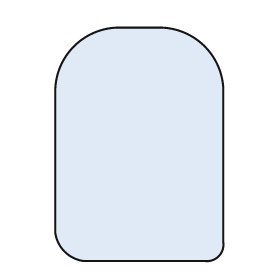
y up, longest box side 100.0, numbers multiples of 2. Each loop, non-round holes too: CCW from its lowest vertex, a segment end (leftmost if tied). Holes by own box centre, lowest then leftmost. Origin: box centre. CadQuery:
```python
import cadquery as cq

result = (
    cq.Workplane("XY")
    .moveTo(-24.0, -50.0)
    .lineTo(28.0, -50.0)
    .threePointArc((34.0, -48.0), (36.0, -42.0))
    .lineTo(36.0, 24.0)
    .threePointArc((28.0, 42.0), (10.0, 50.0))
    .lineTo(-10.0, 50.0)
    .threePointArc((-28.0, 42.0), (-36.0, 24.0))
    .lineTo(-36.0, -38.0)
    .threePointArc((-32.0, -46.0), (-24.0, -50.0))
    .close()
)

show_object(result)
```